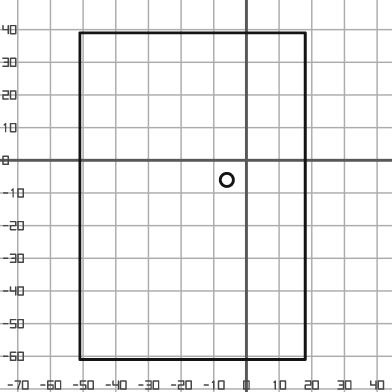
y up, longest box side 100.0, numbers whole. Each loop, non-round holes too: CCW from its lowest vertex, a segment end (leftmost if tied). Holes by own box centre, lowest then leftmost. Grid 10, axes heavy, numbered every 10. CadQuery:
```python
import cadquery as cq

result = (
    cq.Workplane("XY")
    .moveTo(-51.0, -61.0)
    .lineTo(18.0, -61.0)
    .lineTo(18.0, 39.0)
    .lineTo(-51.0, 39.0)
    .close()
    .moveTo(-6.0, -6.0)
    .circle(2.0)
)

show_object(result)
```